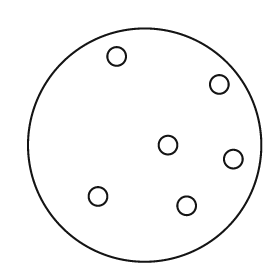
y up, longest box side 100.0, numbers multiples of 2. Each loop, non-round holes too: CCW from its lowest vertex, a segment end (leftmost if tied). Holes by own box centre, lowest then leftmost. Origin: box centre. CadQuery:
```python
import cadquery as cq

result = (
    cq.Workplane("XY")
    .moveTo(0.0, 0.0)
    .circle(50.0)
    .moveTo(18.0, -26.0)
    .circle(4.0)
    .moveTo(-20.0, -22.0)
    .circle(4.0)
    .moveTo(38.0, -6.0)
    .circle(4.0)
    .moveTo(10.0, 0.0)
    .circle(4.0)
    .moveTo(32.0, 26.0)
    .circle(4.0)
    .moveTo(-12.0, 38.0)
    .circle(4.0)
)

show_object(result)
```